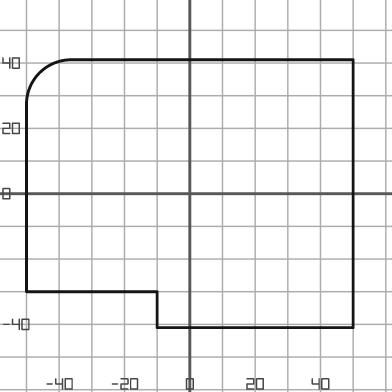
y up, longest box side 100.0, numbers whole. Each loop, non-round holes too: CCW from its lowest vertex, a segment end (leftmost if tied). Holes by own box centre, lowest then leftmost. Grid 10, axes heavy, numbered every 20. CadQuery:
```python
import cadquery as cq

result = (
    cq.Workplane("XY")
    .moveTo(-10.0, -41.0)
    .lineTo(50.0, -41.0)
    .lineTo(50.0, 41.0)
    .lineTo(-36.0, 41.0)
    .threePointArc((-46.0, 37.0), (-50.0, 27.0))
    .lineTo(-50.0, -30.0)
    .lineTo(-10.0, -30.0)
    .close()
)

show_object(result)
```